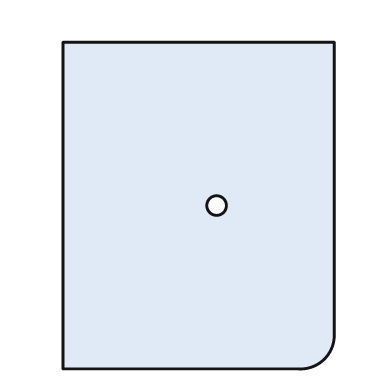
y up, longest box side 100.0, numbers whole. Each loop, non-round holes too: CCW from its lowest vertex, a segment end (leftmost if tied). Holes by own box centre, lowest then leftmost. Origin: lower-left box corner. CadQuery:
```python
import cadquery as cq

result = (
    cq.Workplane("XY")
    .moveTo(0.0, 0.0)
    .lineTo(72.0, 0.0)
    .threePointArc((80.0, 3.0), (83.0, 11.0))
    .lineTo(83.0, 100.0)
    .lineTo(0.0, 100.0)
    .close()
    .moveTo(47.0, 50.0)
    .circle(3.0)
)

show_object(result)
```